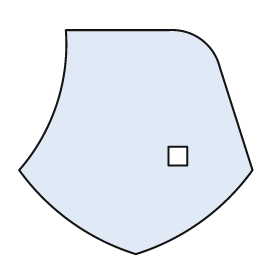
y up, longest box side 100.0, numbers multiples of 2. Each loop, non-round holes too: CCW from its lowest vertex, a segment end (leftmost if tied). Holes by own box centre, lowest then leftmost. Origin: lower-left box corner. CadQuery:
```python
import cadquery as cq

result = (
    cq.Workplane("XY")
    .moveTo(50.0, 0.0)
    .threePointArc((78.0, 14.0), (100.0, 36.0))
    .lineTo(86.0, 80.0)
    .threePointArc((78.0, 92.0), (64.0, 96.0))
    .lineTo(20.0, 96.0)
    .threePointArc((16.0, 64.0), (0.0, 36.0))
    .threePointArc((22.0, 14.0), (50.0, 0.0))
    .close()
    .moveTo(64.0, 38.0)
    .lineTo(72.0, 38.0)
    .lineTo(72.0, 46.0)
    .lineTo(64.0, 46.0)
    .close()
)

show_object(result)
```